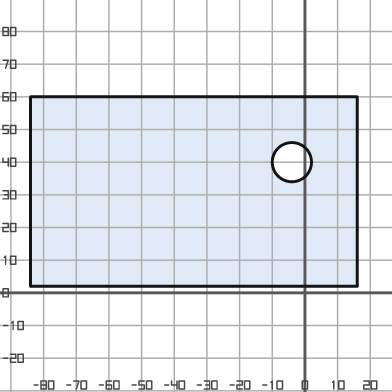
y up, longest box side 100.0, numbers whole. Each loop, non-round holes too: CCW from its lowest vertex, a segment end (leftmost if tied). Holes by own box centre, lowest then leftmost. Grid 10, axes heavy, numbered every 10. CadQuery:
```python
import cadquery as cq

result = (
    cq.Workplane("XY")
    .moveTo(-84.0, 2.0)
    .lineTo(16.0, 2.0)
    .lineTo(16.0, 60.0)
    .lineTo(-84.0, 60.0)
    .close()
    .moveTo(-4.0, 40.0)
    .circle(6.0)
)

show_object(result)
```